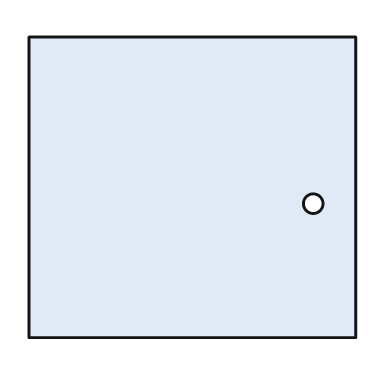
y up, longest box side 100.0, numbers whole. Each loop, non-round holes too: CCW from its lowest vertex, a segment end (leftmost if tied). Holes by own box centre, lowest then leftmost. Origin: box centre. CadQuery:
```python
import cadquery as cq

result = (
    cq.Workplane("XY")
    .moveTo(-50.0, -46.0)
    .lineTo(50.0, -46.0)
    .lineTo(50.0, 46.0)
    .lineTo(-50.0, 46.0)
    .close()
    .moveTo(37.0, -5.0)
    .circle(3.0)
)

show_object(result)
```